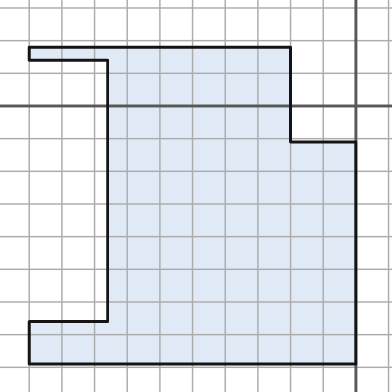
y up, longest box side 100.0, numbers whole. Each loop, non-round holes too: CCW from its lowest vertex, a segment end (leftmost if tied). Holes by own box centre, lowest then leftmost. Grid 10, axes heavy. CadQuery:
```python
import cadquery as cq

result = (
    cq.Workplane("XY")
    .moveTo(-100.0, -79.0)
    .lineTo(0.0, -79.0)
    .lineTo(0.0, -11.0)
    .lineTo(-20.0, -11.0)
    .lineTo(-20.0, 18.0)
    .lineTo(-100.0, 18.0)
    .lineTo(-100.0, 14.0)
    .lineTo(-76.0, 14.0)
    .lineTo(-76.0, -66.0)
    .lineTo(-100.0, -66.0)
    .close()
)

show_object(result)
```